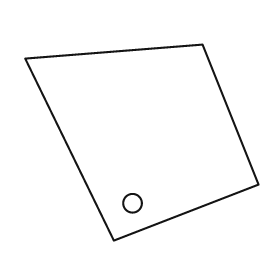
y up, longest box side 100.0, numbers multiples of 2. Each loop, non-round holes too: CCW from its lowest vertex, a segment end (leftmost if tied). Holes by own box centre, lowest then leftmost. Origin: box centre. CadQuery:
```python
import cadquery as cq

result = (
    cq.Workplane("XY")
    .moveTo(-12.0, -42.0)
    .lineTo(50.0, -18.0)
    .lineTo(26.0, 42.0)
    .lineTo(-50.0, 36.0)
    .close()
    .moveTo(-4.0, -26.0)
    .circle(4.0)
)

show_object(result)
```